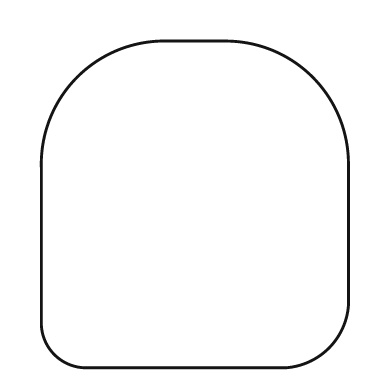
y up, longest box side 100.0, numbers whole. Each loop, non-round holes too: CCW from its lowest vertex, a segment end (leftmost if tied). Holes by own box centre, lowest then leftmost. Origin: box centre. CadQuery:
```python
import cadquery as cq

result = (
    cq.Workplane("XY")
    .moveTo(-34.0, -50.0)
    .lineTo(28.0, -50.0)
    .threePointArc((41.0, -44.0), (47.0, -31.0))
    .lineTo(47.0, 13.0)
    .threePointArc((36.0, 39.0), (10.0, 50.0))
    .lineTo(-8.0, 50.0)
    .threePointArc((-36.0, 39.0), (-47.0, 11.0))
    .lineTo(-47.0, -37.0)
    .threePointArc((-43.0, -46.0), (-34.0, -50.0))
    .close()
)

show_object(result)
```